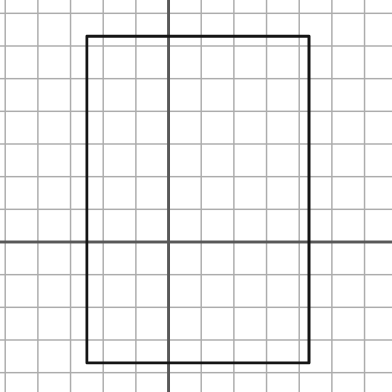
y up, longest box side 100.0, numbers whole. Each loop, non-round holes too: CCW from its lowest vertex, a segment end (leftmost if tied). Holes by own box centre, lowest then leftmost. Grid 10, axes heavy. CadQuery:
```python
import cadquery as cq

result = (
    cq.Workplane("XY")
    .moveTo(-25.0, -37.0)
    .lineTo(43.0, -37.0)
    .lineTo(43.0, 63.0)
    .lineTo(-25.0, 63.0)
    .close()
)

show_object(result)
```